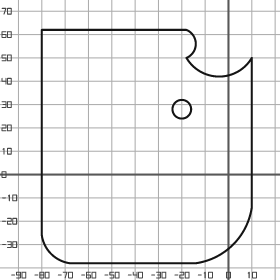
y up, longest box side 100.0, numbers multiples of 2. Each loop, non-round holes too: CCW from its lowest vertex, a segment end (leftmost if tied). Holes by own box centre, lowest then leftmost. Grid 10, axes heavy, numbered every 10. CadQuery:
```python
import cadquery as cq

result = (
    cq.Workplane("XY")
    .moveTo(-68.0, -38.0)
    .lineTo(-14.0, -38.0)
    .threePointArc((2.0, -30.0), (10.0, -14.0))
    .lineTo(10.0, 50.0)
    .threePointArc((-4.0, 42.0), (-18.0, 50.0))
    .threePointArc((-14.0, 56.0), (-18.0, 62.0))
    .lineTo(-80.0, 62.0)
    .lineTo(-80.0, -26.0)
    .threePointArc((-76.0, -34.0), (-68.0, -38.0))
    .close()
    .moveTo(-20.0, 28.0)
    .circle(4.0)
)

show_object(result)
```